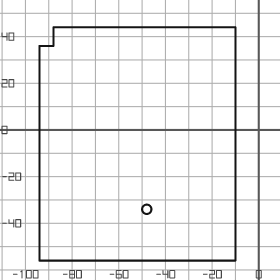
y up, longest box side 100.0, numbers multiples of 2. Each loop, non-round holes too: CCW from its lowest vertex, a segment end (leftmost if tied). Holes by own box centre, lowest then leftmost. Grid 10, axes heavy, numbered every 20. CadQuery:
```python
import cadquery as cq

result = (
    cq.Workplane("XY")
    .moveTo(-94.0, -56.0)
    .lineTo(-10.0, -56.0)
    .lineTo(-10.0, 44.0)
    .lineTo(-88.0, 44.0)
    .lineTo(-88.0, 36.0)
    .lineTo(-94.0, 36.0)
    .close()
    .moveTo(-48.0, -34.0)
    .circle(2.0)
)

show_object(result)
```